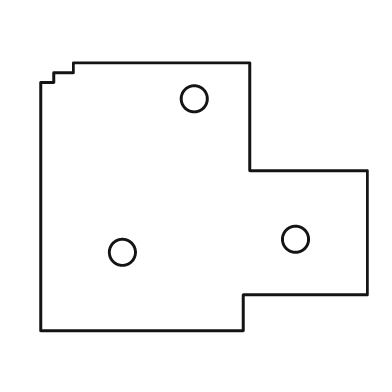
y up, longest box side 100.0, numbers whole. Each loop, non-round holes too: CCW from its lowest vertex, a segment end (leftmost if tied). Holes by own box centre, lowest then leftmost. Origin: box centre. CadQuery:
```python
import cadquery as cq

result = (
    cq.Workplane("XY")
    .moveTo(-50.0, -41.0)
    .lineTo(12.0, -41.0)
    .lineTo(12.0, -30.0)
    .lineTo(50.0, -30.0)
    .lineTo(50.0, 8.0)
    .lineTo(14.0, 8.0)
    .lineTo(14.0, 41.0)
    .lineTo(-40.0, 41.0)
    .lineTo(-40.0, 38.0)
    .lineTo(-46.0, 38.0)
    .lineTo(-46.0, 35.0)
    .lineTo(-50.0, 35.0)
    .close()
    .moveTo(-25.0, -17.0)
    .circle(4.0)
    .moveTo(28.0, -13.0)
    .circle(4.0)
    .moveTo(-3.0, 30.0)
    .circle(4.0)
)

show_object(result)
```